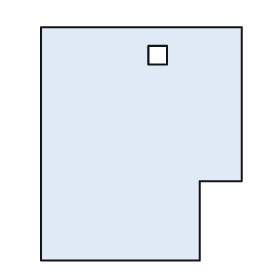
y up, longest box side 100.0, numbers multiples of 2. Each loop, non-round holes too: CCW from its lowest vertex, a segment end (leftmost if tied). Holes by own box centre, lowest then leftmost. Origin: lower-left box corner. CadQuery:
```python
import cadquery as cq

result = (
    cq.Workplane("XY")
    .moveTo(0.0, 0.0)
    .lineTo(68.0, 0.0)
    .lineTo(68.0, 34.0)
    .lineTo(86.0, 34.0)
    .lineTo(86.0, 100.0)
    .lineTo(0.0, 100.0)
    .close()
    .moveTo(46.0, 84.0)
    .lineTo(54.0, 84.0)
    .lineTo(54.0, 92.0)
    .lineTo(46.0, 92.0)
    .close()
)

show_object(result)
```